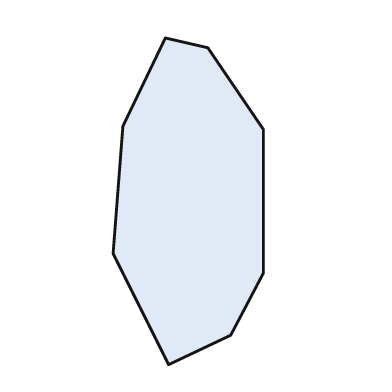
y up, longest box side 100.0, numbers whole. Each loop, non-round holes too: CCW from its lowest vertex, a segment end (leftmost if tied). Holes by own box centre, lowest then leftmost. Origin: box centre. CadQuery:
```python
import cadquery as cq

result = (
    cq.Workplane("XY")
    .moveTo(-6.0, -50.0)
    .lineTo(13.0, -41.0)
    .lineTo(23.0, -22.0)
    .lineTo(23.0, 22.0)
    .lineTo(6.0, 47.0)
    .lineTo(-7.0, 50.0)
    .lineTo(-20.0, 23.0)
    .lineTo(-23.0, -16.0)
    .close()
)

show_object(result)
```